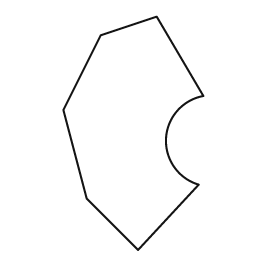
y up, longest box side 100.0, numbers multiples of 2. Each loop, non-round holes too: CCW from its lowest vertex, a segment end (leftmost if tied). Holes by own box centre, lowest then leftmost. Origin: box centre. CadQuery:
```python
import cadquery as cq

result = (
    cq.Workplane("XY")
    .moveTo(2.0, -50.0)
    .lineTo(28.0, -22.0)
    .threePointArc((14.0, -2.0), (30.0, 16.0))
    .lineTo(10.0, 50.0)
    .lineTo(-14.0, 42.0)
    .lineTo(-30.0, 10.0)
    .lineTo(-20.0, -28.0)
    .close()
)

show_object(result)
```